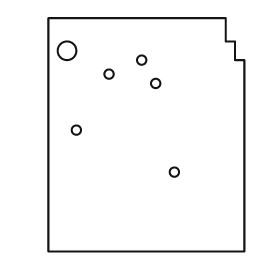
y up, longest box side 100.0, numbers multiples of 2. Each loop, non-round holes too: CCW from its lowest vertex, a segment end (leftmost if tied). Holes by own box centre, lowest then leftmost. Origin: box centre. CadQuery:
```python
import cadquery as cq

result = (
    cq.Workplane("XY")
    .moveTo(-42.0, -50.0)
    .lineTo(42.0, -50.0)
    .lineTo(42.0, 32.0)
    .lineTo(38.0, 32.0)
    .lineTo(38.0, 40.0)
    .lineTo(34.0, 40.0)
    .lineTo(34.0, 50.0)
    .lineTo(-42.0, 50.0)
    .close()
    .moveTo(12.0, -16.0)
    .circle(2.0)
    .moveTo(-30.0, 2.0)
    .circle(2.0)
    .moveTo(4.0, 22.0)
    .circle(2.0)
    .moveTo(-16.0, 26.0)
    .circle(2.0)
    .moveTo(-2.0, 32.0)
    .circle(2.0)
    .moveTo(-34.0, 36.0)
    .circle(4.0)
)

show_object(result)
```